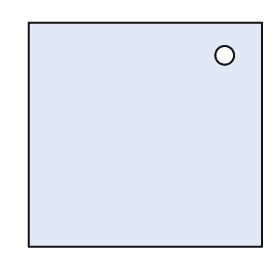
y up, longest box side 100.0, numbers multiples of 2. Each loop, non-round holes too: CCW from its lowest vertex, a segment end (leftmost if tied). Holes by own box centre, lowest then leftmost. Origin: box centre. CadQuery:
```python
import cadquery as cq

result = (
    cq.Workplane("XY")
    .moveTo(-50.0, -48.0)
    .lineTo(50.0, -48.0)
    .lineTo(50.0, 48.0)
    .lineTo(-50.0, 48.0)
    .close()
    .moveTo(34.0, 34.0)
    .circle(4.0)
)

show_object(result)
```